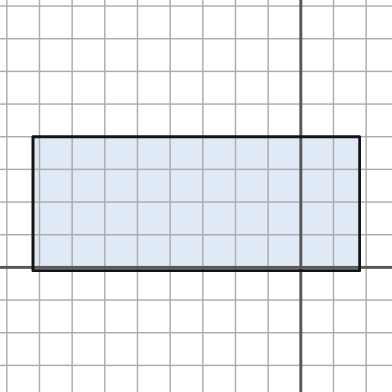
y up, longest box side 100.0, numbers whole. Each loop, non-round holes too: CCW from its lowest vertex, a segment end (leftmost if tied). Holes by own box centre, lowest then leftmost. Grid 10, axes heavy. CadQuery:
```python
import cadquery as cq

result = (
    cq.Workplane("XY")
    .moveTo(-82.0, -1.0)
    .lineTo(18.0, -1.0)
    .lineTo(18.0, 40.0)
    .lineTo(-82.0, 40.0)
    .close()
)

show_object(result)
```